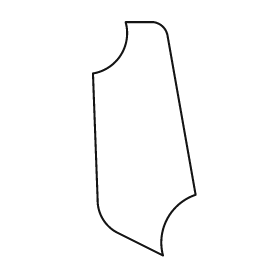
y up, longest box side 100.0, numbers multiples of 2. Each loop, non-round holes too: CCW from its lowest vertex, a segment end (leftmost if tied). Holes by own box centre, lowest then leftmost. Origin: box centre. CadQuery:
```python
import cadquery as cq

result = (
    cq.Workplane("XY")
    .moveTo(8.0, -50.0)
    .threePointArc((10.0, -34.0), (22.0, -24.0))
    .lineTo(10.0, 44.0)
    .threePointArc((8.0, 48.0), (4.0, 50.0))
    .lineTo(-8.0, 50.0)
    .threePointArc((-10.0, 36.0), (-22.0, 28.0))
    .lineTo(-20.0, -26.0)
    .threePointArc((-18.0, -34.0), (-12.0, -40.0))
    .close()
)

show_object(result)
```